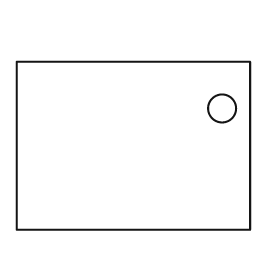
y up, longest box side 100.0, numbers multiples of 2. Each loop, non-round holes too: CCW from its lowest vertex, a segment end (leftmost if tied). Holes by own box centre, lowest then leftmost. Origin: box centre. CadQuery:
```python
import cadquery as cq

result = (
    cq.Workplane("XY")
    .moveTo(-50.0, -36.0)
    .lineTo(50.0, -36.0)
    .lineTo(50.0, 36.0)
    .lineTo(-50.0, 36.0)
    .close()
    .moveTo(38.0, 16.0)
    .circle(6.0)
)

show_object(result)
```